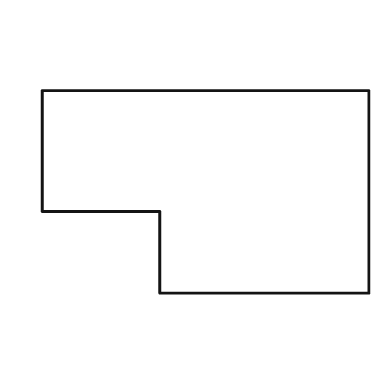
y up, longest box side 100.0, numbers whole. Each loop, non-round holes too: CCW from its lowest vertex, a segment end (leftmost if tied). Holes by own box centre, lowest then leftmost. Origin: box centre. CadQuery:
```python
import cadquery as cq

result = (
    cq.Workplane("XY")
    .moveTo(-14.0, -31.0)
    .lineTo(50.0, -31.0)
    .lineTo(50.0, 31.0)
    .lineTo(-50.0, 31.0)
    .lineTo(-50.0, -6.0)
    .lineTo(-14.0, -6.0)
    .close()
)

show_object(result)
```